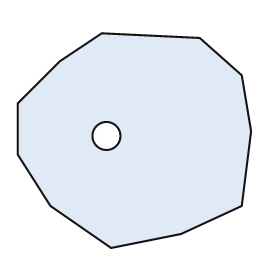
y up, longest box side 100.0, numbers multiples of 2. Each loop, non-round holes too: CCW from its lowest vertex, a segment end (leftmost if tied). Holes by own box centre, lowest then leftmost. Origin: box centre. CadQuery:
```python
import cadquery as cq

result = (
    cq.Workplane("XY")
    .moveTo(-10.0, -46.0)
    .lineTo(20.0, -40.0)
    .lineTo(46.0, -28.0)
    .lineTo(50.0, 4.0)
    .lineTo(46.0, 28.0)
    .lineTo(28.0, 44.0)
    .lineTo(-14.0, 46.0)
    .lineTo(-32.0, 34.0)
    .lineTo(-50.0, 16.0)
    .lineTo(-50.0, -6.0)
    .lineTo(-36.0, -28.0)
    .close()
    .moveTo(-12.0, 2.0)
    .circle(6.0)
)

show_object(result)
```